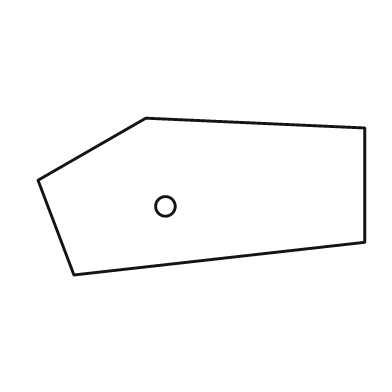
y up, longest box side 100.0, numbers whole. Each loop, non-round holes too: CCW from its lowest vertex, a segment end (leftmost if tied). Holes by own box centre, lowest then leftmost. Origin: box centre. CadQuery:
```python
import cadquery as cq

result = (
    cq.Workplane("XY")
    .moveTo(-39.0, -24.0)
    .lineTo(50.0, -14.0)
    .lineTo(50.0, 21.0)
    .lineTo(-17.0, 24.0)
    .lineTo(-50.0, 5.0)
    .close()
    .moveTo(-11.0, -3.0)
    .circle(3.0)
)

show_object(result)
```